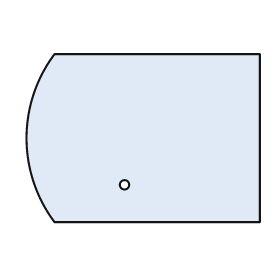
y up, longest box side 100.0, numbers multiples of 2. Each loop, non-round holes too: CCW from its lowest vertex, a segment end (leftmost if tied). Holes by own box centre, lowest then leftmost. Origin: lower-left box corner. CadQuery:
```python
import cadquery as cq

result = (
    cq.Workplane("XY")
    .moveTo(12.0, 0.0)
    .lineTo(100.0, 0.0)
    .lineTo(100.0, 72.0)
    .lineTo(12.0, 72.0)
    .threePointArc((0.0, 36.0), (12.0, 0.0))
    .close()
    .moveTo(42.0, 16.0)
    .circle(2.0)
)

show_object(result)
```